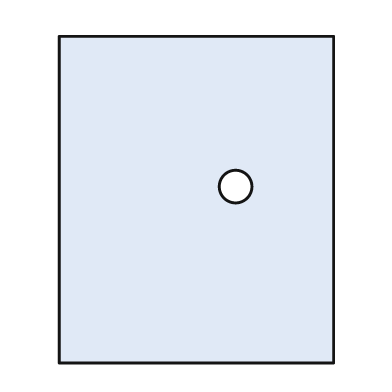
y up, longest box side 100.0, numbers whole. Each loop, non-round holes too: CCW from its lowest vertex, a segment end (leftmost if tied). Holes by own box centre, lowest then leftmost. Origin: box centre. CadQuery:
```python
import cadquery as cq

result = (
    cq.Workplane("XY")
    .moveTo(-42.0, -50.0)
    .lineTo(42.0, -50.0)
    .lineTo(42.0, 50.0)
    .lineTo(-42.0, 50.0)
    .close()
    .moveTo(12.0, 4.0)
    .circle(5.0)
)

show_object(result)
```